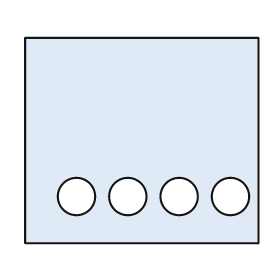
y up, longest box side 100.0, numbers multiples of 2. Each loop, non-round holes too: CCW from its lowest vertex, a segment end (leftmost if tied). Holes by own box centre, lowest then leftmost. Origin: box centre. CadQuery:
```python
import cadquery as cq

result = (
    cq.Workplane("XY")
    .moveTo(-50.0, -44.0)
    .lineTo(50.0, -44.0)
    .lineTo(50.0, 44.0)
    .lineTo(-50.0, 44.0)
    .close()
    .moveTo(-28.0, -24.0)
    .circle(8.0)
    .moveTo(-6.0, -24.0)
    .circle(8.0)
    .moveTo(16.0, -24.0)
    .circle(8.0)
    .moveTo(38.0, -24.0)
    .circle(8.0)
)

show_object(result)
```